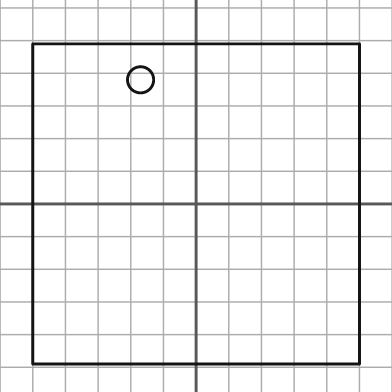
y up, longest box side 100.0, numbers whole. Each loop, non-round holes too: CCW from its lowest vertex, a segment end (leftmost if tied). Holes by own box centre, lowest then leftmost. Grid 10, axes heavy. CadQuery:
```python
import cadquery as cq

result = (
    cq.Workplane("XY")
    .moveTo(-50.0, -49.0)
    .lineTo(50.0, -49.0)
    .lineTo(50.0, 49.0)
    .lineTo(-50.0, 49.0)
    .close()
    .moveTo(-17.0, 38.0)
    .circle(4.0)
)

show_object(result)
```